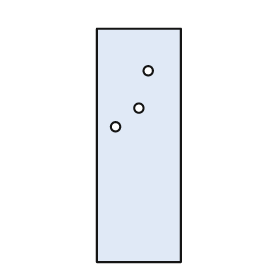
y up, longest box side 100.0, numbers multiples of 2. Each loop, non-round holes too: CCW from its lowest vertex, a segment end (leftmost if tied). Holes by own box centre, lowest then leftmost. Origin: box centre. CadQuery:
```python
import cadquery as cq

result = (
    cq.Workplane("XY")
    .moveTo(-18.0, -50.0)
    .lineTo(18.0, -50.0)
    .lineTo(18.0, 50.0)
    .lineTo(-18.0, 50.0)
    .close()
    .moveTo(-10.0, 8.0)
    .circle(2.0)
    .moveTo(0.0, 16.0)
    .circle(2.0)
    .moveTo(4.0, 32.0)
    .circle(2.0)
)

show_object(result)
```